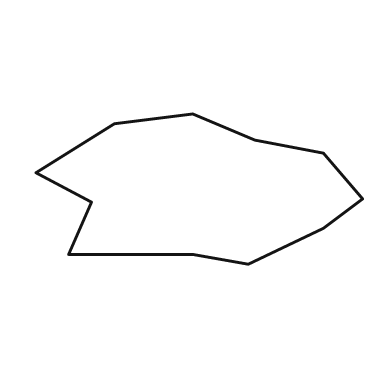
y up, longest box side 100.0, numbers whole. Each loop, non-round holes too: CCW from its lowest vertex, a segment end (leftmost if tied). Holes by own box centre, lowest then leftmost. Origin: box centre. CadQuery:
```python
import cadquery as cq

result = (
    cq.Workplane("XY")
    .moveTo(15.0, -23.0)
    .lineTo(38.0, -12.0)
    .lineTo(50.0, -3.0)
    .lineTo(38.0, 11.0)
    .lineTo(17.0, 15.0)
    .lineTo(-2.0, 23.0)
    .lineTo(-26.0, 20.0)
    .lineTo(-50.0, 5.0)
    .lineTo(-33.0, -4.0)
    .lineTo(-40.0, -20.0)
    .lineTo(-2.0, -20.0)
    .close()
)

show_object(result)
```